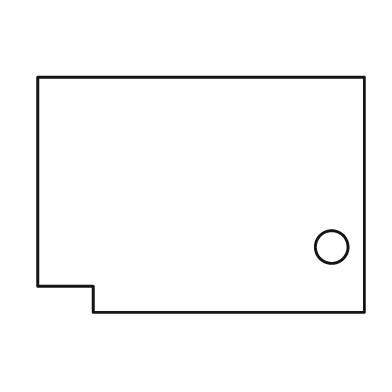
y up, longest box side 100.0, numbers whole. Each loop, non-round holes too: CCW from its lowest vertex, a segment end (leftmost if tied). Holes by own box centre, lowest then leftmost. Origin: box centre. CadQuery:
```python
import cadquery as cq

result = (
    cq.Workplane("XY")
    .moveTo(-33.0, -36.0)
    .lineTo(50.0, -36.0)
    .lineTo(50.0, 36.0)
    .lineTo(-50.0, 36.0)
    .lineTo(-50.0, -28.0)
    .lineTo(-33.0, -28.0)
    .close()
    .moveTo(40.0, -16.0)
    .circle(5.0)
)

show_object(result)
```